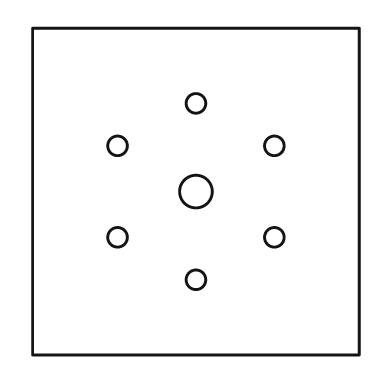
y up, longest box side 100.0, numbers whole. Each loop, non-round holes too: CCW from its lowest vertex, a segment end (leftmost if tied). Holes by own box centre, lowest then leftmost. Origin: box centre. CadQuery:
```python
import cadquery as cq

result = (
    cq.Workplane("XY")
    .moveTo(-50.0, -50.0)
    .lineTo(50.0, -50.0)
    .lineTo(50.0, 50.0)
    .lineTo(-50.0, 50.0)
    .close()
    .moveTo(0.0, -27.0)
    .circle(3.0)
    .moveTo(-24.0, -14.0)
    .circle(3.0)
    .moveTo(24.0, -14.0)
    .circle(3.0)
    .moveTo(0.0, 0.0)
    .circle(5.0)
    .moveTo(-24.0, 14.0)
    .circle(3.0)
    .moveTo(24.0, 14.0)
    .circle(3.0)
    .moveTo(0.0, 27.0)
    .circle(3.0)
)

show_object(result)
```